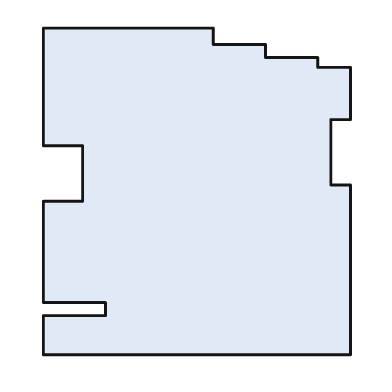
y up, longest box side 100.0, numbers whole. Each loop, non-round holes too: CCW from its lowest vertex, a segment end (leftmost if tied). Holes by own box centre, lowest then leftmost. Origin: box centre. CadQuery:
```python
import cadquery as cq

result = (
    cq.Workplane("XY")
    .moveTo(-47.0, -50.0)
    .lineTo(47.0, -50.0)
    .lineTo(47.0, 2.0)
    .lineTo(41.0, 2.0)
    .lineTo(41.0, 22.0)
    .lineTo(47.0, 22.0)
    .lineTo(47.0, 38.0)
    .lineTo(37.0, 38.0)
    .lineTo(37.0, 41.0)
    .lineTo(21.0, 41.0)
    .lineTo(21.0, 45.0)
    .lineTo(5.0, 45.0)
    .lineTo(5.0, 50.0)
    .lineTo(-47.0, 50.0)
    .lineTo(-47.0, 14.0)
    .lineTo(-35.0, 14.0)
    .lineTo(-35.0, -3.0)
    .lineTo(-47.0, -3.0)
    .lineTo(-47.0, -34.0)
    .lineTo(-28.0, -34.0)
    .lineTo(-28.0, -38.0)
    .lineTo(-47.0, -38.0)
    .close()
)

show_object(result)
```